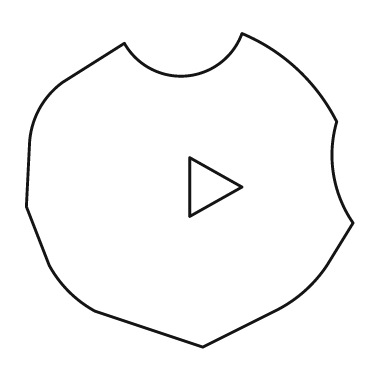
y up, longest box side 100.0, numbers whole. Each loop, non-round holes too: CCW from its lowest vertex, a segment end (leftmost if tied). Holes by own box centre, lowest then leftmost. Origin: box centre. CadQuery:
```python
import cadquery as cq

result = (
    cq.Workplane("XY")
    .moveTo(4.0, -48.0)
    .lineTo(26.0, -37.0)
    .threePointArc((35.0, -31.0), (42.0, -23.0))
    .lineTo(50.0, -10.0)
    .threePointArc((44.0, 5.0), (45.0, 21.0))
    .threePointArc((33.0, 37.0), (16.0, 48.0))
    .threePointArc((-1.0, 35.0), (-20.0, 45.0))
    .lineTo(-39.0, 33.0)
    .threePointArc((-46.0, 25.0), (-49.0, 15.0))
    .lineTo(-50.0, -5.0)
    .lineTo(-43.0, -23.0)
    .threePointArc((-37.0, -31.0), (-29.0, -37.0))
    .close()
    .moveTo(0.0, -8.0)
    .lineTo(16.0, 1.0)
    .lineTo(0.0, 10.0)
    .close()
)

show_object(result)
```